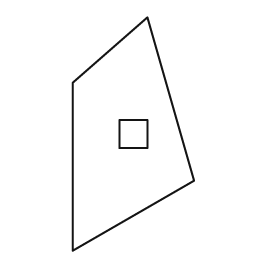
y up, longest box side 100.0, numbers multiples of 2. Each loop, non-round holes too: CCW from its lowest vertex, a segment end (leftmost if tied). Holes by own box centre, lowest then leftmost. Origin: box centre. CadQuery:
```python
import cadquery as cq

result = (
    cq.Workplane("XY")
    .moveTo(-26.0, -50.0)
    .lineTo(26.0, -20.0)
    .lineTo(6.0, 50.0)
    .lineTo(-26.0, 22.0)
    .close()
    .moveTo(-6.0, -6.0)
    .lineTo(6.0, -6.0)
    .lineTo(6.0, 6.0)
    .lineTo(-6.0, 6.0)
    .close()
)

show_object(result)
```